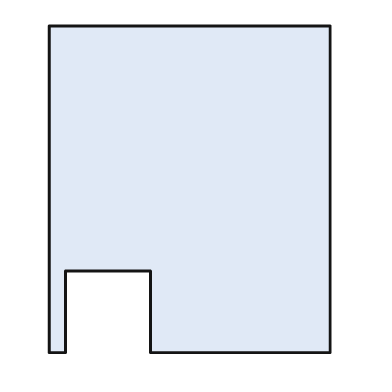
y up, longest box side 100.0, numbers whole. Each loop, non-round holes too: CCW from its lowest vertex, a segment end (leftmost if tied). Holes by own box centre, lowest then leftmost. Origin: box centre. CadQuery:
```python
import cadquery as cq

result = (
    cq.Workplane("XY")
    .moveTo(-43.0, -50.0)
    .lineTo(-38.0, -50.0)
    .lineTo(-38.0, -25.0)
    .lineTo(-12.0, -25.0)
    .lineTo(-12.0, -50.0)
    .lineTo(43.0, -50.0)
    .lineTo(43.0, 50.0)
    .lineTo(-43.0, 50.0)
    .close()
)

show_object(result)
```